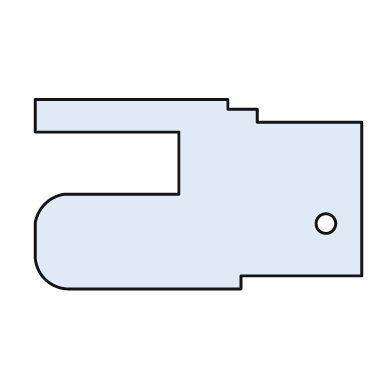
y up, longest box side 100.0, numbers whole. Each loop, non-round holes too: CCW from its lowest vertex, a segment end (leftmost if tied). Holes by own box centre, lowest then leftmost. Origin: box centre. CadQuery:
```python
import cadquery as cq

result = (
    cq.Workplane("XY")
    .moveTo(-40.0, -29.0)
    .lineTo(13.0, -29.0)
    .lineTo(13.0, -25.0)
    .lineTo(50.0, -25.0)
    .lineTo(50.0, 22.0)
    .lineTo(18.0, 22.0)
    .lineTo(18.0, 26.0)
    .lineTo(9.0, 26.0)
    .lineTo(9.0, 29.0)
    .lineTo(-50.0, 29.0)
    .lineTo(-50.0, 19.0)
    .lineTo(-6.0, 19.0)
    .lineTo(-6.0, 0.0)
    .lineTo(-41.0, 0.0)
    .threePointArc((-47.0, -3.0), (-50.0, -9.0))
    .lineTo(-50.0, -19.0)
    .threePointArc((-47.0, -26.0), (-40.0, -29.0))
    .close()
    .moveTo(39.0, -9.0)
    .circle(3.0)
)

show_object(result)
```